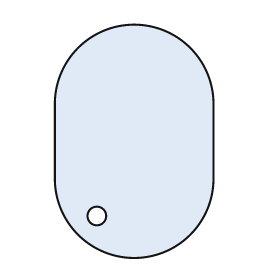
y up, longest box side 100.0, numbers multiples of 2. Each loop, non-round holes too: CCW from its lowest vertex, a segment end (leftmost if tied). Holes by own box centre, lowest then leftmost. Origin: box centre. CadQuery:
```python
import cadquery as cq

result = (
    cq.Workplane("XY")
    .moveTo(-34.0, -16.0)
    .threePointArc((0.0, -50.0), (34.0, -16.0))
    .lineTo(34.0, 16.0)
    .threePointArc((0.0, 50.0), (-34.0, 16.0))
    .close()
    .moveTo(-16.0, -32.0)
    .circle(4.0)
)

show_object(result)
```